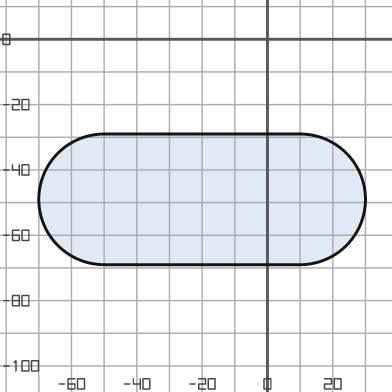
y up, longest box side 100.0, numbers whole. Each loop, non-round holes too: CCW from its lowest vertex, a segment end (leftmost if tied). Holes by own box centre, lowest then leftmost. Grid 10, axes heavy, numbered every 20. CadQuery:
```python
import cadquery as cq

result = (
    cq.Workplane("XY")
    .moveTo(-50.0, -69.0)
    .lineTo(10.0, -69.0)
    .threePointArc((30.0, -49.0), (10.0, -29.0))
    .lineTo(-50.0, -29.0)
    .threePointArc((-70.0, -49.0), (-50.0, -69.0))
    .close()
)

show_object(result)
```